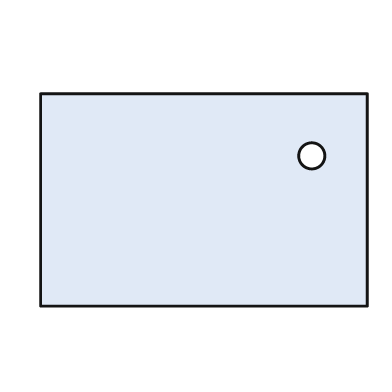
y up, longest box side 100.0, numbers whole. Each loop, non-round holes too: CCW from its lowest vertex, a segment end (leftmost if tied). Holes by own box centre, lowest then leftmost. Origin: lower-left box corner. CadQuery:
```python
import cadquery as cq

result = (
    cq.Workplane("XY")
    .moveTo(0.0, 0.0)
    .lineTo(100.0, 0.0)
    .lineTo(100.0, 65.0)
    .lineTo(0.0, 65.0)
    .close()
    .moveTo(83.0, 46.0)
    .circle(4.0)
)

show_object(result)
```